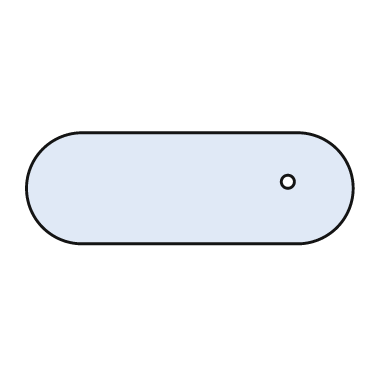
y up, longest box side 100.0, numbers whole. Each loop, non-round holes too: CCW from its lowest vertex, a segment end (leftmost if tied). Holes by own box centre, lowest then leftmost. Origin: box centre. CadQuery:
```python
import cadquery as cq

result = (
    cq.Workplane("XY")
    .moveTo(-33.0, -17.0)
    .lineTo(33.0, -17.0)
    .threePointArc((50.0, 0.0), (33.0, 17.0))
    .lineTo(-33.0, 17.0)
    .threePointArc((-50.0, 0.0), (-33.0, -17.0))
    .close()
    .moveTo(30.0, 2.0)
    .circle(2.0)
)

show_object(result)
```